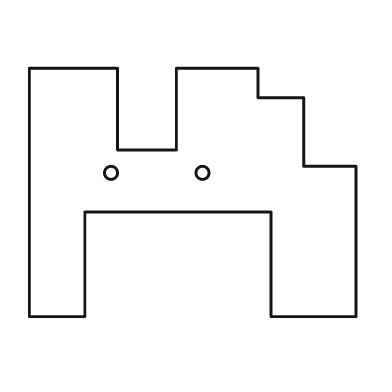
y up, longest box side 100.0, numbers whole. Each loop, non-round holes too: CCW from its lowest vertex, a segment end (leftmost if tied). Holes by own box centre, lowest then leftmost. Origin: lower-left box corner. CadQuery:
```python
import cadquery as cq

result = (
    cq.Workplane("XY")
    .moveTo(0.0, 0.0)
    .lineTo(17.0, 0.0)
    .lineTo(17.0, 32.0)
    .lineTo(74.0, 32.0)
    .lineTo(74.0, 0.0)
    .lineTo(100.0, 0.0)
    .lineTo(100.0, 46.0)
    .lineTo(84.0, 46.0)
    .lineTo(84.0, 67.0)
    .lineTo(70.0, 67.0)
    .lineTo(70.0, 76.0)
    .lineTo(45.0, 76.0)
    .lineTo(45.0, 51.0)
    .lineTo(27.0, 51.0)
    .lineTo(27.0, 76.0)
    .lineTo(0.0, 76.0)
    .close()
    .moveTo(25.0, 44.0)
    .circle(2.0)
    .moveTo(53.0, 44.0)
    .circle(2.0)
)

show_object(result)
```